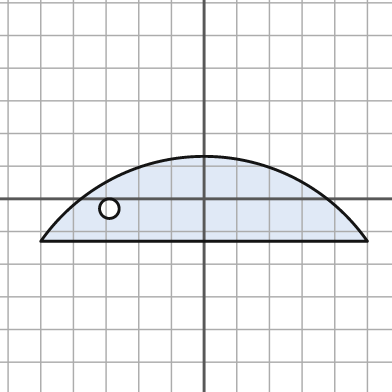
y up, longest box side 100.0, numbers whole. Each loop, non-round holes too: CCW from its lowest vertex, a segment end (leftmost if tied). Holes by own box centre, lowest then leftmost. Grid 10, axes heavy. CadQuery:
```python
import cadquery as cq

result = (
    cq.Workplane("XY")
    .moveTo(-50.0, -13.0)
    .lineTo(50.0, -13.0)
    .threePointArc((0.0, 13.0), (-50.0, -13.0))
    .close()
    .moveTo(-29.0, -3.0)
    .circle(3.0)
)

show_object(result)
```